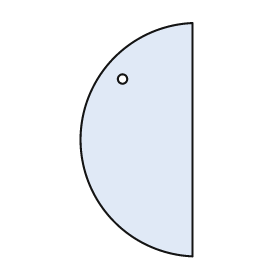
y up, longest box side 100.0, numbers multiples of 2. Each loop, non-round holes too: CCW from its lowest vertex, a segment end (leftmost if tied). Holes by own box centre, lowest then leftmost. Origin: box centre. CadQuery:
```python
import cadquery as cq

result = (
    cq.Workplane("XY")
    .moveTo(24.0, -50.0)
    .lineTo(24.0, 50.0)
    .threePointArc((-24.0, 0.0), (24.0, -50.0))
    .close()
    .moveTo(-6.0, 26.0)
    .circle(2.0)
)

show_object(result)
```